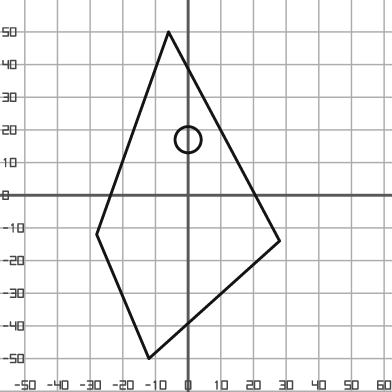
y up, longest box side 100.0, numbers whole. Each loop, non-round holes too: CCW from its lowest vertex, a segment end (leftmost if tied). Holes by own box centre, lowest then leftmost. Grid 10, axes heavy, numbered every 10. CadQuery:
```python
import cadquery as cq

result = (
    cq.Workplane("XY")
    .moveTo(-12.0, -50.0)
    .lineTo(28.0, -14.0)
    .lineTo(-6.0, 50.0)
    .lineTo(-28.0, -12.0)
    .close()
    .moveTo(0.0, 17.0)
    .circle(4.0)
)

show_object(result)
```